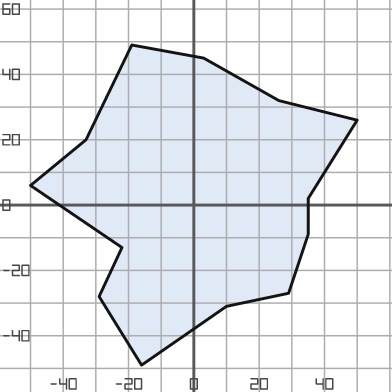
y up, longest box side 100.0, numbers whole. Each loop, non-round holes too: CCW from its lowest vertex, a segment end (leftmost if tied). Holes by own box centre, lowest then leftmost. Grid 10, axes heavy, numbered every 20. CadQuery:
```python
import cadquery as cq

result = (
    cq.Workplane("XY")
    .moveTo(-16.0, -49.0)
    .lineTo(10.0, -31.0)
    .lineTo(29.0, -27.0)
    .lineTo(35.0, -9.0)
    .lineTo(35.0, 2.0)
    .lineTo(50.0, 26.0)
    .lineTo(26.0, 32.0)
    .lineTo(3.0, 45.0)
    .lineTo(-19.0, 49.0)
    .lineTo(-33.0, 20.0)
    .lineTo(-50.0, 6.0)
    .lineTo(-22.0, -13.0)
    .lineTo(-29.0, -28.0)
    .close()
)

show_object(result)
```